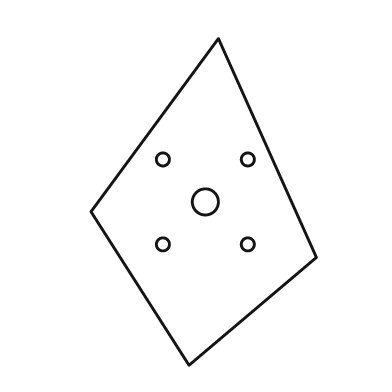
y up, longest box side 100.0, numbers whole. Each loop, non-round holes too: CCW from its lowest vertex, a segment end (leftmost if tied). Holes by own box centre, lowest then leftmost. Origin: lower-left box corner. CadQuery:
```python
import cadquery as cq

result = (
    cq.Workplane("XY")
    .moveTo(30.0, 0.0)
    .lineTo(69.0, 33.0)
    .lineTo(39.0, 100.0)
    .lineTo(0.0, 47.0)
    .close()
    .moveTo(22.0, 37.0)
    .circle(2.0)
    .moveTo(48.0, 37.0)
    .circle(2.0)
    .moveTo(35.0, 50.0)
    .circle(4.0)
    .moveTo(22.0, 63.0)
    .circle(2.0)
    .moveTo(48.0, 63.0)
    .circle(2.0)
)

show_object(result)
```